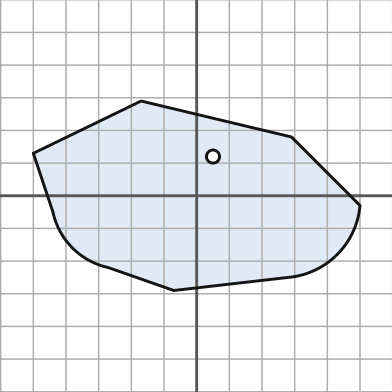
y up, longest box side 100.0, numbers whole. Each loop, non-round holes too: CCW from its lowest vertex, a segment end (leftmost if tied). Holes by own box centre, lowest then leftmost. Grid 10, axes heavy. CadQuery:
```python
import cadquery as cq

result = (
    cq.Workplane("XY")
    .moveTo(-7.0, -29.0)
    .lineTo(28.0, -25.0)
    .threePointArc((43.0, -18.0), (50.0, -3.0))
    .lineTo(29.0, 18.0)
    .lineTo(-17.0, 29.0)
    .lineTo(-50.0, 13.0)
    .lineTo(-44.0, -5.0)
    .threePointArc((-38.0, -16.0), (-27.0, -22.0))
    .close()
    .moveTo(5.0, 12.0)
    .circle(2.0)
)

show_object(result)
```